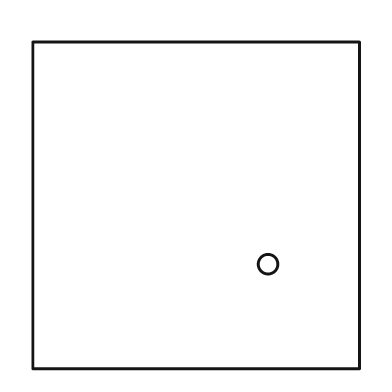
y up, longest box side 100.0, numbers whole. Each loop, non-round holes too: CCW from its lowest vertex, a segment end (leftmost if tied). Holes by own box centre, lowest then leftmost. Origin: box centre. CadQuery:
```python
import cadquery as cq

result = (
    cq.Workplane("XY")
    .moveTo(-50.0, -50.0)
    .lineTo(50.0, -50.0)
    .lineTo(50.0, 50.0)
    .lineTo(-50.0, 50.0)
    .close()
    .moveTo(22.0, -18.0)
    .circle(3.0)
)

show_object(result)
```